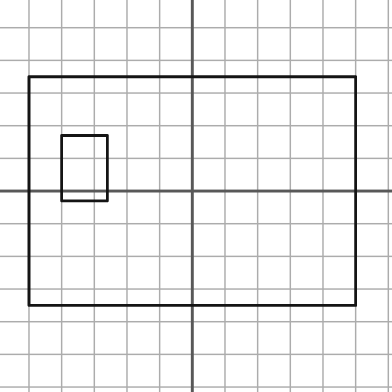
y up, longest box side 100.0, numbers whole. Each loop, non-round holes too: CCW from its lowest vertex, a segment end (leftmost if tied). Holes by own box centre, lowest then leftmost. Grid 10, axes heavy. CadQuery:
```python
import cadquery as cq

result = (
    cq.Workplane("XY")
    .moveTo(-50.0, -35.0)
    .lineTo(50.0, -35.0)
    .lineTo(50.0, 35.0)
    .lineTo(-50.0, 35.0)
    .close()
    .moveTo(-40.0, -3.0)
    .lineTo(-26.0, -3.0)
    .lineTo(-26.0, 17.0)
    .lineTo(-40.0, 17.0)
    .close()
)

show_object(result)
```